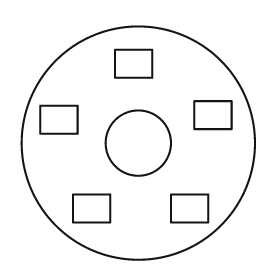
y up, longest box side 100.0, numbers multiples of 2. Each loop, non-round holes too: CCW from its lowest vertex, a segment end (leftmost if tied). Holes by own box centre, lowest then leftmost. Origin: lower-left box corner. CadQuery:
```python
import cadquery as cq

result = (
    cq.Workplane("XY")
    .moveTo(50.0, 50.0)
    .circle(50.0)
    .moveTo(22.0, 16.0)
    .lineTo(38.0, 16.0)
    .lineTo(38.0, 28.0)
    .lineTo(22.0, 28.0)
    .close()
    .moveTo(64.0, 16.0)
    .lineTo(80.0, 16.0)
    .lineTo(80.0, 28.0)
    .lineTo(64.0, 28.0)
    .close()
    .moveTo(50.0, 50.0)
    .circle(14.0)
    .moveTo(8.0, 54.0)
    .lineTo(24.0, 54.0)
    .lineTo(24.0, 66.0)
    .lineTo(8.0, 66.0)
    .close()
    .moveTo(74.0, 56.0)
    .lineTo(90.0, 56.0)
    .lineTo(90.0, 68.0)
    .lineTo(74.0, 68.0)
    .close()
    .moveTo(40.0, 78.0)
    .lineTo(56.0, 78.0)
    .lineTo(56.0, 90.0)
    .lineTo(40.0, 90.0)
    .close()
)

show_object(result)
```